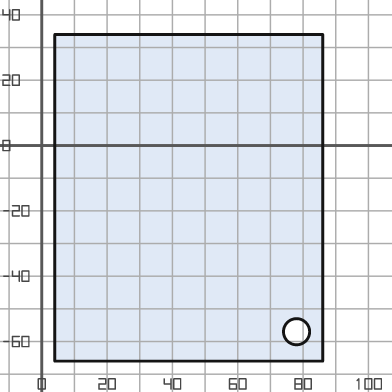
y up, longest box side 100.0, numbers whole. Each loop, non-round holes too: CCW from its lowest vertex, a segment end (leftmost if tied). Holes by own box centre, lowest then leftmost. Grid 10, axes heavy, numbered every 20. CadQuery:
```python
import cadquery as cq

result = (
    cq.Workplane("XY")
    .moveTo(4.0, -66.0)
    .lineTo(86.0, -66.0)
    .lineTo(86.0, 34.0)
    .lineTo(4.0, 34.0)
    .close()
    .moveTo(78.0, -57.0)
    .circle(4.0)
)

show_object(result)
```